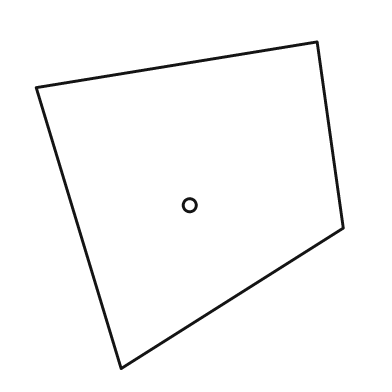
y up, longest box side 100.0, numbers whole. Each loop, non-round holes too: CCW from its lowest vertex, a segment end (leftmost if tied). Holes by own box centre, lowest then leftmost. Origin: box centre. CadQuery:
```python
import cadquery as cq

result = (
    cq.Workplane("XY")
    .moveTo(-21.0, -50.0)
    .lineTo(47.0, -7.0)
    .lineTo(39.0, 50.0)
    .lineTo(-47.0, 36.0)
    .close()
    .moveTo(0.0, 0.0)
    .circle(2.0)
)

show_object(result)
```